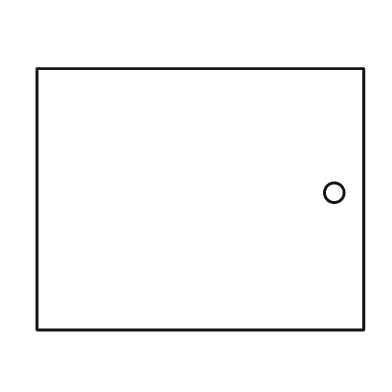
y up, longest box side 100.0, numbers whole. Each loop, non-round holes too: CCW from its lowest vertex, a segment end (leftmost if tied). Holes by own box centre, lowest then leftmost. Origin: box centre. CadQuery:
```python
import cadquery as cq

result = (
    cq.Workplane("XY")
    .moveTo(-50.0, -40.0)
    .lineTo(50.0, -40.0)
    .lineTo(50.0, 40.0)
    .lineTo(-50.0, 40.0)
    .close()
    .moveTo(41.0, 2.0)
    .circle(3.0)
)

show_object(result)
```